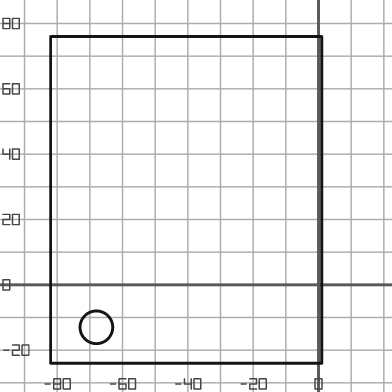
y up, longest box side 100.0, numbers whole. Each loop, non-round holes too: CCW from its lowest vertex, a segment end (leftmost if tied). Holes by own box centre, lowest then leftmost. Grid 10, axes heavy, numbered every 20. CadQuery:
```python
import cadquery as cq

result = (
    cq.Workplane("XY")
    .moveTo(-82.0, -24.0)
    .lineTo(1.0, -24.0)
    .lineTo(1.0, 76.0)
    .lineTo(-82.0, 76.0)
    .close()
    .moveTo(-68.0, -13.0)
    .circle(5.0)
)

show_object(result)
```